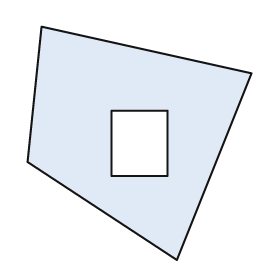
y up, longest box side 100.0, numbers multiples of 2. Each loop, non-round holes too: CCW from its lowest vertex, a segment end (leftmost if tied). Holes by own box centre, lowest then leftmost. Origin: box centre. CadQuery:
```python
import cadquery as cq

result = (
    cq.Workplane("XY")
    .moveTo(16.0, -50.0)
    .lineTo(48.0, 30.0)
    .lineTo(-42.0, 50.0)
    .lineTo(-48.0, -8.0)
    .close()
    .moveTo(-12.0, -14.0)
    .lineTo(12.0, -14.0)
    .lineTo(12.0, 14.0)
    .lineTo(-12.0, 14.0)
    .close()
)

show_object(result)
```